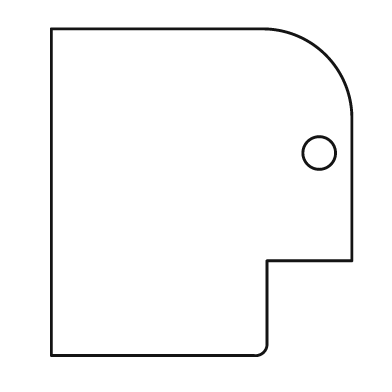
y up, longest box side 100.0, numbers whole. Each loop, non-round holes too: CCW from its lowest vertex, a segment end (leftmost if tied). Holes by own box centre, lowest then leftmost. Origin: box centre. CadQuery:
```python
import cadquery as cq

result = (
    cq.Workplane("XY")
    .moveTo(-46.0, -50.0)
    .lineTo(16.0, -50.0)
    .threePointArc((19.0, -49.0), (20.0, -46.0))
    .lineTo(20.0, -21.0)
    .lineTo(46.0, -21.0)
    .lineTo(46.0, 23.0)
    .threePointArc((38.0, 42.0), (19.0, 50.0))
    .lineTo(-46.0, 50.0)
    .close()
    .moveTo(36.0, 12.0)
    .circle(5.0)
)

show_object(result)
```